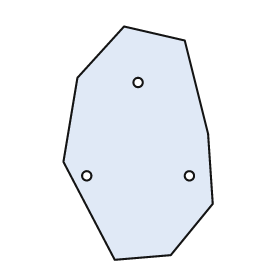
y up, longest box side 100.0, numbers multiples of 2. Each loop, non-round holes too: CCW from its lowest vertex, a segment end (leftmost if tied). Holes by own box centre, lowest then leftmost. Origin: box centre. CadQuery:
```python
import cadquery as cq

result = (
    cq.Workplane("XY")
    .moveTo(-10.0, -50.0)
    .lineTo(14.0, -48.0)
    .lineTo(32.0, -26.0)
    .lineTo(30.0, 4.0)
    .lineTo(20.0, 44.0)
    .lineTo(-6.0, 50.0)
    .lineTo(-26.0, 28.0)
    .lineTo(-32.0, -8.0)
    .close()
    .moveTo(-22.0, -14.0)
    .circle(2.0)
    .moveTo(22.0, -14.0)
    .circle(2.0)
    .moveTo(0.0, 26.0)
    .circle(2.0)
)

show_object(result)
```